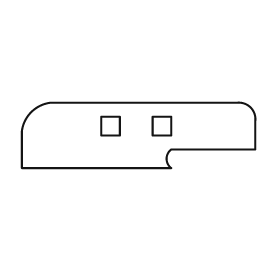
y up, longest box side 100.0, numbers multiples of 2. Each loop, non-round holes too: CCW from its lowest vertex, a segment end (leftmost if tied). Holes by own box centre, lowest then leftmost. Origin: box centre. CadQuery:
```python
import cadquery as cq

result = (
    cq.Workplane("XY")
    .moveTo(-50.0, -14.0)
    .lineTo(14.0, -14.0)
    .threePointArc((12.0, -10.0), (14.0, -6.0))
    .lineTo(50.0, -6.0)
    .lineTo(50.0, 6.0)
    .threePointArc((48.0, 12.0), (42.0, 14.0))
    .lineTo(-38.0, 14.0)
    .threePointArc((-46.0, 10.0), (-50.0, 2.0))
    .close()
    .moveTo(-16.0, 0.0)
    .lineTo(-8.0, 0.0)
    .lineTo(-8.0, 8.0)
    .lineTo(-16.0, 8.0)
    .close()
    .moveTo(6.0, 0.0)
    .lineTo(14.0, 0.0)
    .lineTo(14.0, 8.0)
    .lineTo(6.0, 8.0)
    .close()
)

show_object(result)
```